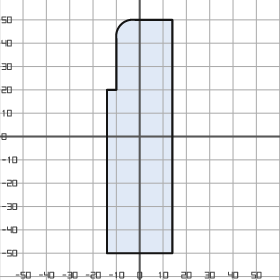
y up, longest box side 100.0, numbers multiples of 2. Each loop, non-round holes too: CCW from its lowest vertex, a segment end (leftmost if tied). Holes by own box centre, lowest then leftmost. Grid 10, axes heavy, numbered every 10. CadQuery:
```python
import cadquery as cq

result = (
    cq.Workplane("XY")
    .moveTo(-14.0, -50.0)
    .lineTo(14.0, -50.0)
    .lineTo(14.0, 50.0)
    .lineTo(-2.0, 50.0)
    .threePointArc((-8.0, 48.0), (-10.0, 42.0))
    .lineTo(-10.0, 20.0)
    .lineTo(-14.0, 20.0)
    .close()
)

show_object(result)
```